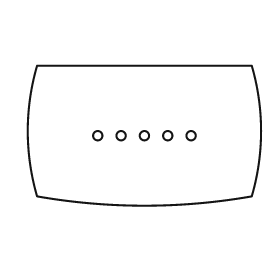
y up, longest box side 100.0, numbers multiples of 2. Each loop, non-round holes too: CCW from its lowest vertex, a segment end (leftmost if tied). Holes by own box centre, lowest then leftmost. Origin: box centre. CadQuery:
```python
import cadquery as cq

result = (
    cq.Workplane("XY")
    .moveTo(-46.0, -26.0)
    .threePointArc((0.0, -30.0), (46.0, -26.0))
    .threePointArc((50.0, 2.0), (46.0, 30.0))
    .lineTo(-46.0, 30.0)
    .threePointArc((-50.0, 2.0), (-46.0, -26.0))
    .close()
    .moveTo(-20.0, 0.0)
    .circle(2.0)
    .moveTo(-10.0, 0.0)
    .circle(2.0)
    .moveTo(0.0, 0.0)
    .circle(2.0)
    .moveTo(10.0, 0.0)
    .circle(2.0)
    .moveTo(20.0, 0.0)
    .circle(2.0)
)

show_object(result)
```